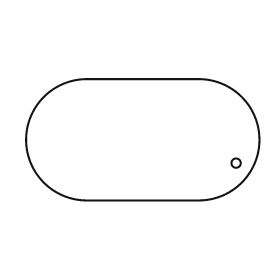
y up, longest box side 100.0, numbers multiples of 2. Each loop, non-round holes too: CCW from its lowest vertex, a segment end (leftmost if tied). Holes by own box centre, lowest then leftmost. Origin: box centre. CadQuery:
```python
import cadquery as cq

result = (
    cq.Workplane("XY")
    .moveTo(-24.0, -26.0)
    .lineTo(24.0, -26.0)
    .threePointArc((50.0, 0.0), (24.0, 26.0))
    .lineTo(-24.0, 26.0)
    .threePointArc((-50.0, 0.0), (-24.0, -26.0))
    .close()
    .moveTo(40.0, -10.0)
    .circle(2.0)
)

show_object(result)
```